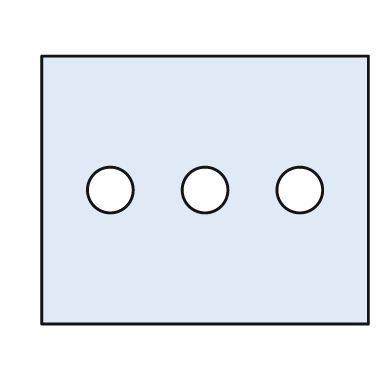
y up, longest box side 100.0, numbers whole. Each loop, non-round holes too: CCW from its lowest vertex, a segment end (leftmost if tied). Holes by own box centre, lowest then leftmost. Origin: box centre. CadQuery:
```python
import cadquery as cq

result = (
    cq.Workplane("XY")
    .moveTo(-50.0, -41.0)
    .lineTo(50.0, -41.0)
    .lineTo(50.0, 41.0)
    .lineTo(-50.0, 41.0)
    .close()
    .moveTo(-29.0, 0.0)
    .circle(7.0)
    .moveTo(0.0, 0.0)
    .circle(7.0)
    .moveTo(29.0, 0.0)
    .circle(7.0)
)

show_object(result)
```